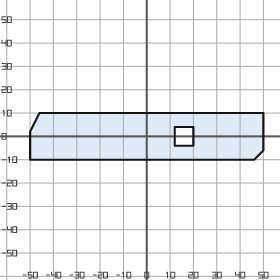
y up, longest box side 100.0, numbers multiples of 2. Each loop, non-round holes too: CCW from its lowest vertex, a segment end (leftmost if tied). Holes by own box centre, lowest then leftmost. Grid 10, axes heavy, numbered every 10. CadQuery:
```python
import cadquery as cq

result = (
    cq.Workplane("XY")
    .moveTo(-50.0, -10.0)
    .lineTo(46.0, -10.0)
    .lineTo(50.0, -6.0)
    .lineTo(50.0, 10.0)
    .lineTo(-46.0, 10.0)
    .lineTo(-50.0, 2.0)
    .close()
    .moveTo(12.0, -4.0)
    .lineTo(20.0, -4.0)
    .lineTo(20.0, 4.0)
    .lineTo(12.0, 4.0)
    .close()
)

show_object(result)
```